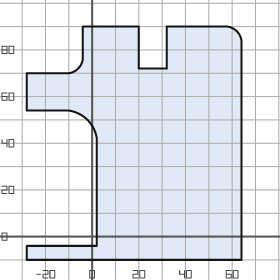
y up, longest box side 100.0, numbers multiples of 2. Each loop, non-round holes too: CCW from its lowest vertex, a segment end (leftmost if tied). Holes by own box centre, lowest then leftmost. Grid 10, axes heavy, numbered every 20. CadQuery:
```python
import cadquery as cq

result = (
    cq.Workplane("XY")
    .moveTo(-28.0, -10.0)
    .lineTo(64.0, -10.0)
    .lineTo(64.0, 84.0)
    .threePointArc((62.0, 88.0), (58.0, 90.0))
    .lineTo(32.0, 90.0)
    .lineTo(32.0, 72.0)
    .lineTo(20.0, 72.0)
    .lineTo(20.0, 90.0)
    .lineTo(-4.0, 90.0)
    .lineTo(-4.0, 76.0)
    .threePointArc((-6.0, 72.0), (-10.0, 70.0))
    .lineTo(-28.0, 70.0)
    .lineTo(-28.0, 54.0)
    .lineTo(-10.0, 54.0)
    .threePointArc((-2.0, 50.0), (2.0, 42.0))
    .lineTo(2.0, -4.0)
    .lineTo(-28.0, -4.0)
    .close()
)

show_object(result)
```